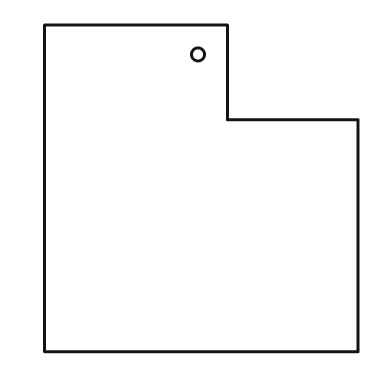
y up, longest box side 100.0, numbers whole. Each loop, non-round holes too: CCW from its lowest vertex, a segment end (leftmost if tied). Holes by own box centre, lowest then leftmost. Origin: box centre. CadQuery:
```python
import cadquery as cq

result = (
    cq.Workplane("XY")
    .moveTo(-48.0, -50.0)
    .lineTo(48.0, -50.0)
    .lineTo(48.0, 21.0)
    .lineTo(8.0, 21.0)
    .lineTo(8.0, 50.0)
    .lineTo(-48.0, 50.0)
    .close()
    .moveTo(-1.0, 41.0)
    .circle(2.0)
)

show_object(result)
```